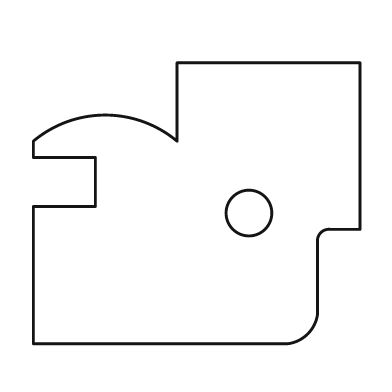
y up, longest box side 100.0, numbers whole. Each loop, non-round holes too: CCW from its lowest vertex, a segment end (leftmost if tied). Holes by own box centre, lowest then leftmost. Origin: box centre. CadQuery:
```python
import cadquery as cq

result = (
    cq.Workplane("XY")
    .moveTo(-50.0, -43.0)
    .lineTo(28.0, -43.0)
    .threePointArc((34.0, -40.0), (37.0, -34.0))
    .lineTo(37.0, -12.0)
    .threePointArc((38.0, -9.0), (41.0, -8.0))
    .lineTo(50.0, -8.0)
    .lineTo(50.0, 43.0)
    .lineTo(-6.0, 43.0)
    .lineTo(-6.0, 19.0)
    .threePointArc((-28.0, 27.0), (-50.0, 19.0))
    .lineTo(-50.0, 14.0)
    .lineTo(-31.0, 14.0)
    .lineTo(-31.0, -1.0)
    .lineTo(-50.0, -1.0)
    .close()
    .moveTo(16.0, -3.0)
    .circle(7.0)
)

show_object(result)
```